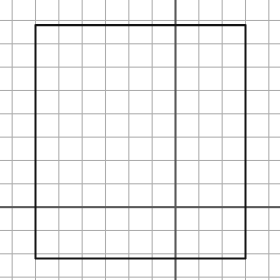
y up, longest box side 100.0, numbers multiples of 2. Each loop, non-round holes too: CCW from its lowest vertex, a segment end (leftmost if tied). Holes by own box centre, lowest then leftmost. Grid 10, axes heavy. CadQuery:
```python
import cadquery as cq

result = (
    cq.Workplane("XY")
    .moveTo(-60.0, -22.0)
    .lineTo(30.0, -22.0)
    .lineTo(30.0, 78.0)
    .lineTo(-60.0, 78.0)
    .close()
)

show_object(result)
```